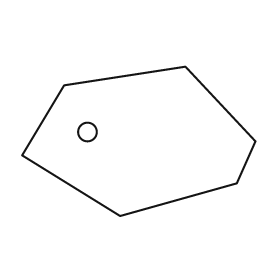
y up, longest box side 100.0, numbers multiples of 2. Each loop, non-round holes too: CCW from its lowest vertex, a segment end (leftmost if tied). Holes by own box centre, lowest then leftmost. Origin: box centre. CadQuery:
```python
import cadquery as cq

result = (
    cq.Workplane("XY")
    .moveTo(-8.0, -32.0)
    .lineTo(42.0, -18.0)
    .lineTo(50.0, 0.0)
    .lineTo(20.0, 32.0)
    .lineTo(-32.0, 24.0)
    .lineTo(-50.0, -6.0)
    .close()
    .moveTo(-22.0, 4.0)
    .circle(4.0)
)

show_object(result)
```